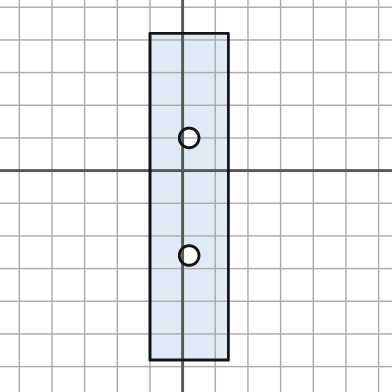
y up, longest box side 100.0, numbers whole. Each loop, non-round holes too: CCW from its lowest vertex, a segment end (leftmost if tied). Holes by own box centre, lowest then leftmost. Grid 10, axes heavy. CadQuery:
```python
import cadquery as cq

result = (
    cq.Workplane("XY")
    .moveTo(-10.0, -58.0)
    .lineTo(14.0, -58.0)
    .lineTo(14.0, 42.0)
    .lineTo(-10.0, 42.0)
    .close()
    .moveTo(2.0, -26.0)
    .circle(3.0)
    .moveTo(2.0, 10.0)
    .circle(3.0)
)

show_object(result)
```